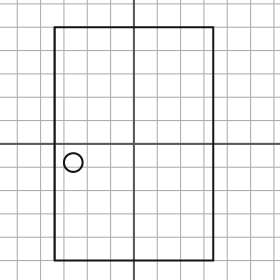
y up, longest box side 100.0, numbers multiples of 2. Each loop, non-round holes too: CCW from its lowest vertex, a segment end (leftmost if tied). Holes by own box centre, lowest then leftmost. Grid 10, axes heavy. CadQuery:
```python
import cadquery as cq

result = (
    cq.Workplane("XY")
    .moveTo(-34.0, -50.0)
    .lineTo(34.0, -50.0)
    .lineTo(34.0, 50.0)
    .lineTo(-34.0, 50.0)
    .close()
    .moveTo(-26.0, -8.0)
    .circle(4.0)
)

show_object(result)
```